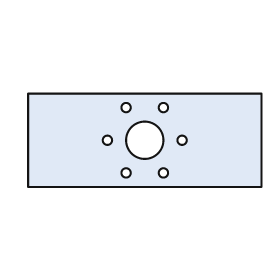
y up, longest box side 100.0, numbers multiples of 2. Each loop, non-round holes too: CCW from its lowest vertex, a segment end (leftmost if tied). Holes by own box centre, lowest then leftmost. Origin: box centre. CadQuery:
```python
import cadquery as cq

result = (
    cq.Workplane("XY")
    .moveTo(-50.0, -20.0)
    .lineTo(50.0, -20.0)
    .lineTo(50.0, 20.0)
    .lineTo(-50.0, 20.0)
    .close()
    .moveTo(-8.0, -14.0)
    .circle(2.0)
    .moveTo(8.0, -14.0)
    .circle(2.0)
    .moveTo(-16.0, 0.0)
    .circle(2.0)
    .moveTo(0.0, 0.0)
    .circle(8.0)
    .moveTo(16.0, 0.0)
    .circle(2.0)
    .moveTo(-8.0, 14.0)
    .circle(2.0)
    .moveTo(8.0, 14.0)
    .circle(2.0)
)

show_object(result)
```